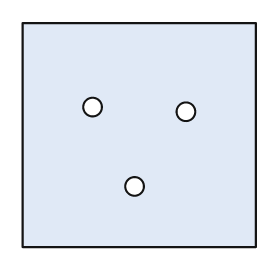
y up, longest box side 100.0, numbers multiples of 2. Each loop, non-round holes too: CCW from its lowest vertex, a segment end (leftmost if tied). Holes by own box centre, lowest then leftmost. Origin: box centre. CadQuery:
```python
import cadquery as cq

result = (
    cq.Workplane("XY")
    .moveTo(-50.0, -48.0)
    .lineTo(50.0, -48.0)
    .lineTo(50.0, 48.0)
    .lineTo(-50.0, 48.0)
    .close()
    .moveTo(-2.0, -22.0)
    .circle(4.0)
    .moveTo(20.0, 10.0)
    .circle(4.0)
    .moveTo(-20.0, 12.0)
    .circle(4.0)
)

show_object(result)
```